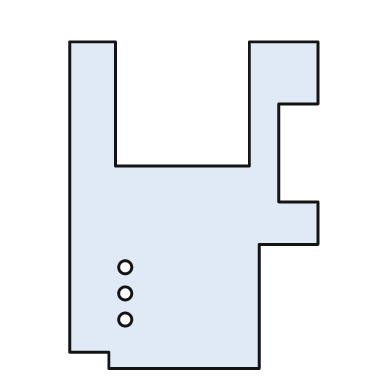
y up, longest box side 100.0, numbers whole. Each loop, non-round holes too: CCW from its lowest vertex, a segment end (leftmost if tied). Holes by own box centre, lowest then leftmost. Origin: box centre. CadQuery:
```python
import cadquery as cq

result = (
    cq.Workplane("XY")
    .moveTo(-26.0, -50.0)
    .lineTo(20.0, -50.0)
    .lineTo(20.0, -12.0)
    .lineTo(38.0, -12.0)
    .lineTo(38.0, 1.0)
    .lineTo(26.0, 1.0)
    .lineTo(26.0, 31.0)
    .lineTo(38.0, 31.0)
    .lineTo(38.0, 50.0)
    .lineTo(17.0, 50.0)
    .lineTo(17.0, 12.0)
    .lineTo(-24.0, 12.0)
    .lineTo(-24.0, 50.0)
    .lineTo(-38.0, 50.0)
    .lineTo(-38.0, -45.0)
    .lineTo(-26.0, -45.0)
    .close()
    .moveTo(-21.0, -35.0)
    .circle(2.0)
    .moveTo(-21.0, -27.0)
    .circle(2.0)
    .moveTo(-21.0, -19.0)
    .circle(2.0)
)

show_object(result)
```